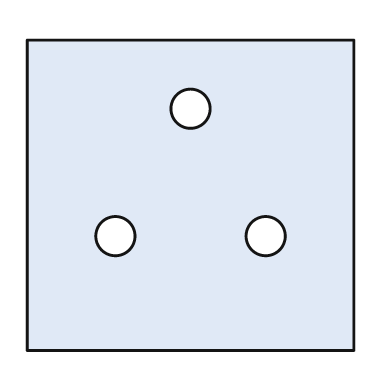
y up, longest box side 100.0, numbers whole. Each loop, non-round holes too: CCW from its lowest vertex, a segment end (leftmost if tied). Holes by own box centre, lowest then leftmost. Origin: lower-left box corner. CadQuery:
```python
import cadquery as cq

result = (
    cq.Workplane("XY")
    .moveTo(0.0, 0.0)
    .lineTo(100.0, 0.0)
    .lineTo(100.0, 95.0)
    .lineTo(0.0, 95.0)
    .close()
    .moveTo(27.0, 35.0)
    .circle(6.0)
    .moveTo(73.0, 35.0)
    .circle(6.0)
    .moveTo(50.0, 74.0)
    .circle(6.0)
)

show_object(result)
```